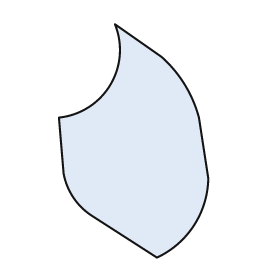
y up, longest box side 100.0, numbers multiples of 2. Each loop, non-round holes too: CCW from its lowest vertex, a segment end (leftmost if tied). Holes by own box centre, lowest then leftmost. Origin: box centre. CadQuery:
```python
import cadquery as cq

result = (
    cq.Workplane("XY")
    .moveTo(10.0, -50.0)
    .threePointArc((26.0, -36.0), (32.0, -16.0))
    .lineTo(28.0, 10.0)
    .threePointArc((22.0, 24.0), (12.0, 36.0))
    .lineTo(-8.0, 50.0)
    .threePointArc((-10.0, 24.0), (-32.0, 10.0))
    .lineTo(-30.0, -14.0)
    .threePointArc((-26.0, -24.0), (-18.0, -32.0))
    .close()
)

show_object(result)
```